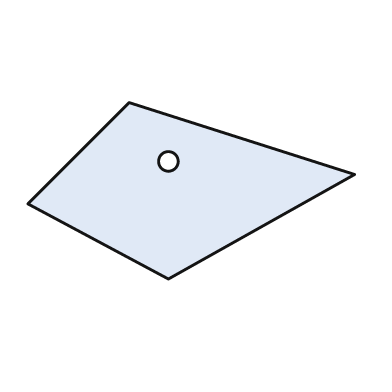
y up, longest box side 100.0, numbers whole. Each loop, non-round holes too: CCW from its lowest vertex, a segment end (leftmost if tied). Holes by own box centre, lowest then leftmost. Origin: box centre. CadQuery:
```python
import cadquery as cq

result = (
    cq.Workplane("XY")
    .moveTo(-7.0, -27.0)
    .lineTo(50.0, 5.0)
    .lineTo(-19.0, 27.0)
    .lineTo(-50.0, -4.0)
    .close()
    .moveTo(-7.0, 9.0)
    .circle(3.0)
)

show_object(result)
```